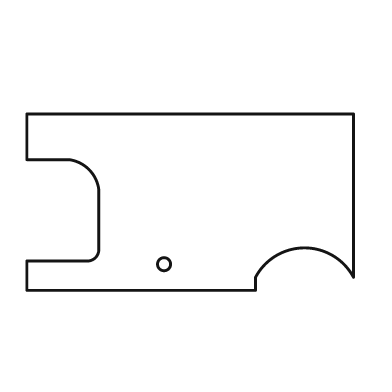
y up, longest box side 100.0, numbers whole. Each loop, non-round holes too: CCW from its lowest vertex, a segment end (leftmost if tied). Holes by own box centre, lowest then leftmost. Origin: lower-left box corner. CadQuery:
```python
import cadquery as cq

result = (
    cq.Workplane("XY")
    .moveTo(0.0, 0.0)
    .lineTo(70.0, 0.0)
    .lineTo(70.0, 4.0)
    .threePointArc((85.0, 13.0), (100.0, 4.0))
    .lineTo(100.0, 54.0)
    .lineTo(0.0, 54.0)
    .lineTo(0.0, 40.0)
    .lineTo(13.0, 40.0)
    .threePointArc((19.0, 37.0), (22.0, 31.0))
    .lineTo(22.0, 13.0)
    .threePointArc((21.0, 10.0), (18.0, 9.0))
    .lineTo(0.0, 9.0)
    .close()
    .moveTo(42.0, 8.0)
    .circle(2.0)
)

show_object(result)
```